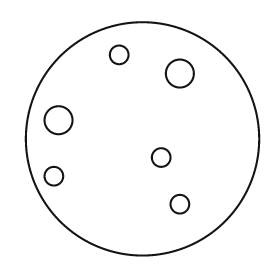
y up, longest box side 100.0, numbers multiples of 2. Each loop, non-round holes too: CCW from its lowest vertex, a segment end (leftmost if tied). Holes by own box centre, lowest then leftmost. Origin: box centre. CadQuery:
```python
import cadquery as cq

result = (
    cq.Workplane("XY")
    .moveTo(0.0, 0.0)
    .circle(50.0)
    .moveTo(16.0, -28.0)
    .circle(4.0)
    .moveTo(-38.0, -16.0)
    .circle(4.0)
    .moveTo(8.0, -8.0)
    .circle(4.0)
    .moveTo(-36.0, 8.0)
    .circle(6.0)
    .moveTo(16.0, 28.0)
    .circle(6.0)
    .moveTo(-10.0, 36.0)
    .circle(4.0)
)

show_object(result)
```